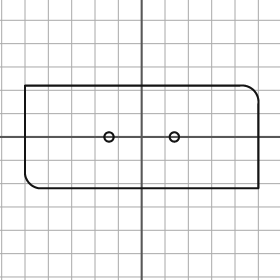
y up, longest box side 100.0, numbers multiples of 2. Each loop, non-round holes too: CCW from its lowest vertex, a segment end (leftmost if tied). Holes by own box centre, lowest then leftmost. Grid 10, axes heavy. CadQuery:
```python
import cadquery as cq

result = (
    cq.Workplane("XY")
    .moveTo(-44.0, -22.0)
    .lineTo(50.0, -22.0)
    .lineTo(50.0, 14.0)
    .threePointArc((48.0, 20.0), (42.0, 22.0))
    .lineTo(-50.0, 22.0)
    .lineTo(-50.0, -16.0)
    .threePointArc((-48.0, -20.0), (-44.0, -22.0))
    .close()
    .moveTo(-14.0, 0.0)
    .circle(2.0)
    .moveTo(14.0, 0.0)
    .circle(2.0)
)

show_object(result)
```